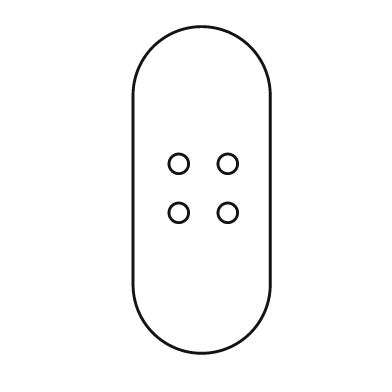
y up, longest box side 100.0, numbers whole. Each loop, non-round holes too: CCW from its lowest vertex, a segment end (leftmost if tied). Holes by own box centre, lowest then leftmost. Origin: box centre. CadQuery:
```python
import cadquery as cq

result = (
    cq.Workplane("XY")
    .moveTo(-21.0, -29.0)
    .threePointArc((0.0, -50.0), (21.0, -29.0))
    .lineTo(21.0, 29.0)
    .threePointArc((0.0, 50.0), (-21.0, 29.0))
    .close()
    .moveTo(-7.0, -7.0)
    .circle(3.0)
    .moveTo(8.0, -7.0)
    .circle(3.0)
    .moveTo(-7.0, 8.0)
    .circle(3.0)
    .moveTo(8.0, 8.0)
    .circle(3.0)
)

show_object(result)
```